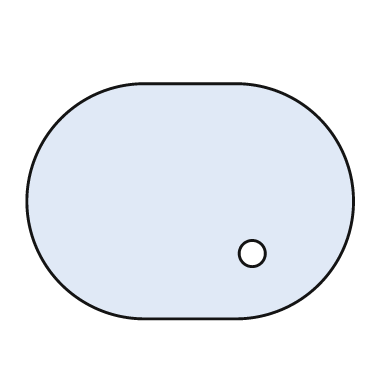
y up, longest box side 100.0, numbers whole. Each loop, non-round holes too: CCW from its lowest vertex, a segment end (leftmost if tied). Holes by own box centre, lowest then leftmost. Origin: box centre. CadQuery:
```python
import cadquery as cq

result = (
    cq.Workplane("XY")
    .moveTo(-14.0, -36.0)
    .lineTo(14.0, -36.0)
    .threePointArc((50.0, 0.0), (14.0, 36.0))
    .lineTo(-14.0, 36.0)
    .threePointArc((-50.0, 0.0), (-14.0, -36.0))
    .close()
    .moveTo(19.0, -16.0)
    .circle(4.0)
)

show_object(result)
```